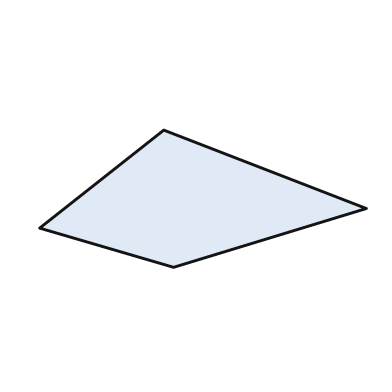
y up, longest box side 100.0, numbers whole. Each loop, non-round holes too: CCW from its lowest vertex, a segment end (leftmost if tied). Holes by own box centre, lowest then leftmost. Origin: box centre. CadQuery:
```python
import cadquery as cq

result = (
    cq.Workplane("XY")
    .moveTo(-9.0, -21.0)
    .lineTo(50.0, -3.0)
    .lineTo(-12.0, 21.0)
    .lineTo(-50.0, -9.0)
    .close()
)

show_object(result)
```